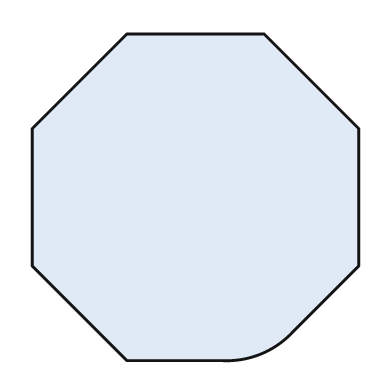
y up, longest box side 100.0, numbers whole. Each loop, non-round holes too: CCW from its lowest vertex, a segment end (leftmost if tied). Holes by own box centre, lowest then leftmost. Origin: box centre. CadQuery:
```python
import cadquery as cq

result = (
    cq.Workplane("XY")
    .moveTo(-21.0, -50.0)
    .lineTo(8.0, -50.0)
    .threePointArc((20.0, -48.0), (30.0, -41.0))
    .lineTo(50.0, -21.0)
    .lineTo(50.0, 21.0)
    .lineTo(21.0, 50.0)
    .lineTo(-21.0, 50.0)
    .lineTo(-50.0, 21.0)
    .lineTo(-50.0, -21.0)
    .close()
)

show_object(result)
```